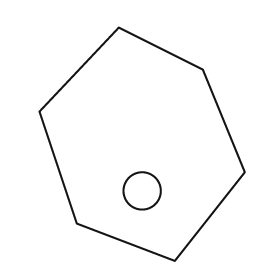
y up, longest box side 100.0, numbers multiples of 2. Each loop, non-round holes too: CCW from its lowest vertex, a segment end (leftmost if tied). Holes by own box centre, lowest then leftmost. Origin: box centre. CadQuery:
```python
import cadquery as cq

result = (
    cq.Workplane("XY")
    .moveTo(14.0, -50.0)
    .lineTo(44.0, -12.0)
    .lineTo(26.0, 32.0)
    .lineTo(-10.0, 50.0)
    .lineTo(-44.0, 14.0)
    .lineTo(-28.0, -34.0)
    .close()
    .moveTo(0.0, -20.0)
    .circle(8.0)
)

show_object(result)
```